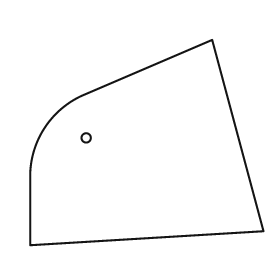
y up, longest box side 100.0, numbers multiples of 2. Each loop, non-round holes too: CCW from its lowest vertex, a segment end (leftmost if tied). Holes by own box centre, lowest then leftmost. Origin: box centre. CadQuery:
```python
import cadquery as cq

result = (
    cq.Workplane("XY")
    .moveTo(-50.0, -44.0)
    .lineTo(50.0, -38.0)
    .lineTo(28.0, 44.0)
    .lineTo(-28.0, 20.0)
    .threePointArc((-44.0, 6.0), (-50.0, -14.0))
    .close()
    .moveTo(-26.0, 2.0)
    .circle(2.0)
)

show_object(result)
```